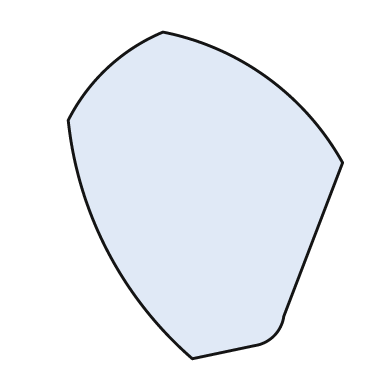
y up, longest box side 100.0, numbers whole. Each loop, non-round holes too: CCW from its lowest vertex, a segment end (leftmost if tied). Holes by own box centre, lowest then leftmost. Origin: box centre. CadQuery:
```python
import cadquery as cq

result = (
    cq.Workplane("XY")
    .moveTo(-4.0, -50.0)
    .lineTo(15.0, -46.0)
    .threePointArc((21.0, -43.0), (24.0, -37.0))
    .lineTo(42.0, 10.0)
    .threePointArc((19.0, 36.0), (-13.0, 50.0))
    .threePointArc((-30.0, 39.0), (-42.0, 23.0))
    .threePointArc((-30.0, -17.0), (-4.0, -50.0))
    .close()
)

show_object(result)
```